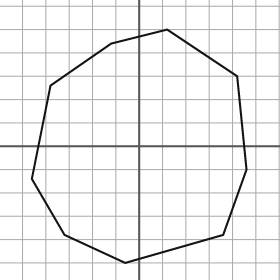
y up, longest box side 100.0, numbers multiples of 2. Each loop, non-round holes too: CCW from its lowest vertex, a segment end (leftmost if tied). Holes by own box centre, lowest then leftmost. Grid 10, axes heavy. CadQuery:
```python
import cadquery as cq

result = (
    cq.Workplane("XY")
    .moveTo(-6.0, -50.0)
    .lineTo(36.0, -38.0)
    .lineTo(46.0, -10.0)
    .lineTo(42.0, 30.0)
    .lineTo(12.0, 50.0)
    .lineTo(-12.0, 44.0)
    .lineTo(-38.0, 26.0)
    .lineTo(-46.0, -14.0)
    .lineTo(-32.0, -38.0)
    .close()
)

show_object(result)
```